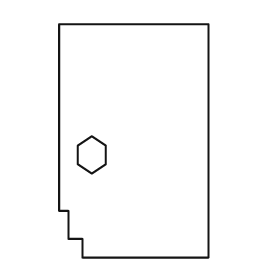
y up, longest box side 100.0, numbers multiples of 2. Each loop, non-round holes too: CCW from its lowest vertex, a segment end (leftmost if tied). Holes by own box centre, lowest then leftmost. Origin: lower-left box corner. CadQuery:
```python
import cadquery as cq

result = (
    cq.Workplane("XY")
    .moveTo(10.0, 0.0)
    .lineTo(64.0, 0.0)
    .lineTo(64.0, 100.0)
    .lineTo(0.0, 100.0)
    .lineTo(0.0, 20.0)
    .lineTo(4.0, 20.0)
    .lineTo(4.0, 8.0)
    .lineTo(10.0, 8.0)
    .close()
    .moveTo(14.0, 36.0)
    .lineTo(20.0, 40.0)
    .lineTo(20.0, 48.0)
    .lineTo(14.0, 52.0)
    .lineTo(8.0, 48.0)
    .lineTo(8.0, 40.0)
    .close()
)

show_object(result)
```